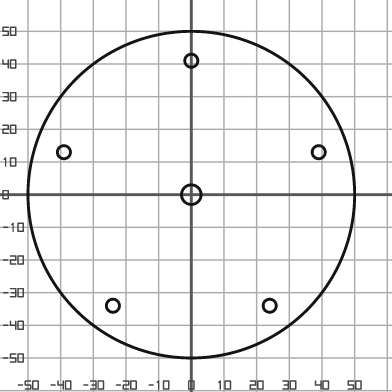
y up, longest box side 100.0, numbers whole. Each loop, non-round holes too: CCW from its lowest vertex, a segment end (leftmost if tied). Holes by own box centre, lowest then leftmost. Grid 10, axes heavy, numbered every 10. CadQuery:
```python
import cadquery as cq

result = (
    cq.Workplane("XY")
    .moveTo(0.0, 0.0)
    .circle(50.0)
    .moveTo(-24.0, -34.0)
    .circle(2.0)
    .moveTo(24.0, -34.0)
    .circle(2.0)
    .moveTo(0.0, 0.0)
    .circle(3.0)
    .moveTo(-39.0, 13.0)
    .circle(2.0)
    .moveTo(39.0, 13.0)
    .circle(2.0)
    .moveTo(0.0, 41.0)
    .circle(2.0)
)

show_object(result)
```